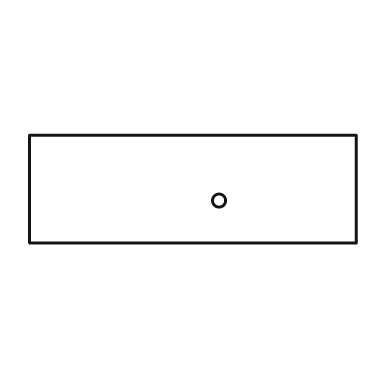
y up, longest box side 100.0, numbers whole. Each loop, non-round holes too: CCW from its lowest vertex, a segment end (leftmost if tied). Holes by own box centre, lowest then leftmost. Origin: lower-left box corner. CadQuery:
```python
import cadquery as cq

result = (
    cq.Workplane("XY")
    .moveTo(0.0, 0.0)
    .lineTo(100.0, 0.0)
    .lineTo(100.0, 33.0)
    .lineTo(0.0, 33.0)
    .close()
    .moveTo(58.0, 13.0)
    .circle(2.0)
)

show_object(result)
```